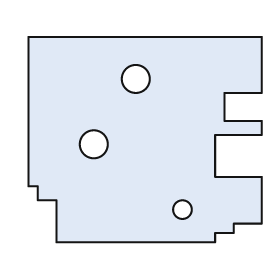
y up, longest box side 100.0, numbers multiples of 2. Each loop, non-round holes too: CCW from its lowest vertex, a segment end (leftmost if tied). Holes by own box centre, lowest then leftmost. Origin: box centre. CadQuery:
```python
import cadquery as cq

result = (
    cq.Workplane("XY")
    .moveTo(-38.0, -44.0)
    .lineTo(30.0, -44.0)
    .lineTo(30.0, -40.0)
    .lineTo(38.0, -40.0)
    .lineTo(38.0, -36.0)
    .lineTo(50.0, -36.0)
    .lineTo(50.0, -16.0)
    .lineTo(30.0, -16.0)
    .lineTo(30.0, 2.0)
    .lineTo(50.0, 2.0)
    .lineTo(50.0, 8.0)
    .lineTo(34.0, 8.0)
    .lineTo(34.0, 20.0)
    .lineTo(50.0, 20.0)
    .lineTo(50.0, 44.0)
    .lineTo(-50.0, 44.0)
    .lineTo(-50.0, -20.0)
    .lineTo(-46.0, -20.0)
    .lineTo(-46.0, -26.0)
    .lineTo(-38.0, -26.0)
    .close()
    .moveTo(16.0, -30.0)
    .circle(4.0)
    .moveTo(-22.0, -2.0)
    .circle(6.0)
    .moveTo(-4.0, 26.0)
    .circle(6.0)
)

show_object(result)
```